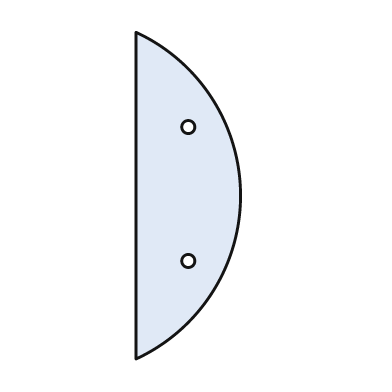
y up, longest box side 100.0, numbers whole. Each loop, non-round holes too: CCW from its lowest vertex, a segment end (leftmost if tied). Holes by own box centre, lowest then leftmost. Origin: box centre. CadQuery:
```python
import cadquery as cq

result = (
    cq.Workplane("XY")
    .moveTo(-16.0, -50.0)
    .threePointArc((16.0, 0.0), (-16.0, 50.0))
    .close()
    .moveTo(0.0, -20.0)
    .circle(2.0)
    .moveTo(0.0, 21.0)
    .circle(2.0)
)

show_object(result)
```